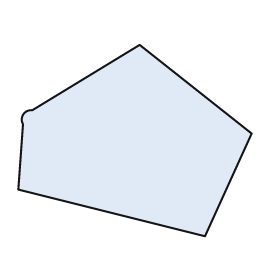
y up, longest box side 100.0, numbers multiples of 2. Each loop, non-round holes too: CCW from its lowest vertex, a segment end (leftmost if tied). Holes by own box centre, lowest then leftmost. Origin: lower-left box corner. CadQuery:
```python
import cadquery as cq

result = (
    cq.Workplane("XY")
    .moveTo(80.0, 0.0)
    .lineTo(100.0, 44.0)
    .lineTo(52.0, 82.0)
    .lineTo(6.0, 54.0)
    .threePointArc((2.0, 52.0), (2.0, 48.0))
    .lineTo(0.0, 20.0)
    .close()
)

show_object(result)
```